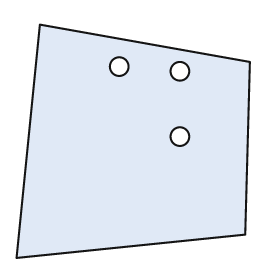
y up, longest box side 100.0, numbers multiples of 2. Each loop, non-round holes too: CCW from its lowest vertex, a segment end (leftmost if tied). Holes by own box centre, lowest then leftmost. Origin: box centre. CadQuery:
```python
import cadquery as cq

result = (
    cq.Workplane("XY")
    .moveTo(-50.0, -50.0)
    .lineTo(48.0, -40.0)
    .lineTo(50.0, 34.0)
    .lineTo(-40.0, 50.0)
    .close()
    .moveTo(20.0, 2.0)
    .circle(4.0)
    .moveTo(20.0, 30.0)
    .circle(4.0)
    .moveTo(-6.0, 32.0)
    .circle(4.0)
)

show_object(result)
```